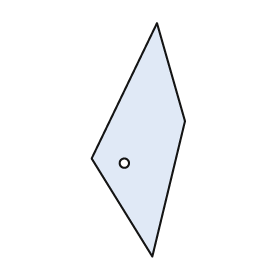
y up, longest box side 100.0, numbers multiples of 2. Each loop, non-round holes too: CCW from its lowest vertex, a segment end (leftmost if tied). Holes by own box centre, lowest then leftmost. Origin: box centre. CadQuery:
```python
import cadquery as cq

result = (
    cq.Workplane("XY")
    .moveTo(6.0, -50.0)
    .lineTo(20.0, 8.0)
    .lineTo(8.0, 50.0)
    .lineTo(-20.0, -8.0)
    .close()
    .moveTo(-6.0, -10.0)
    .circle(2.0)
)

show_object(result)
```